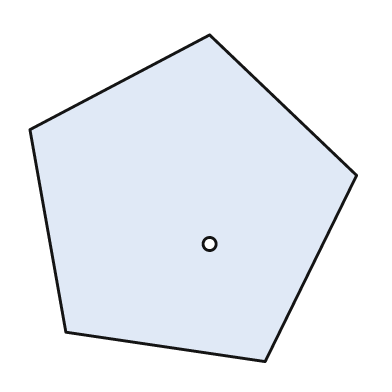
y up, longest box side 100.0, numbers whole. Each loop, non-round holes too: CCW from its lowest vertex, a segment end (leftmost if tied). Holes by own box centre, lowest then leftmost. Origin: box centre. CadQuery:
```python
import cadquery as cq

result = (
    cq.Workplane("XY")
    .moveTo(22.0, -50.0)
    .lineTo(50.0, 7.0)
    .lineTo(5.0, 50.0)
    .lineTo(-50.0, 21.0)
    .lineTo(-39.0, -41.0)
    .close()
    .moveTo(5.0, -14.0)
    .circle(2.0)
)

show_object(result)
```